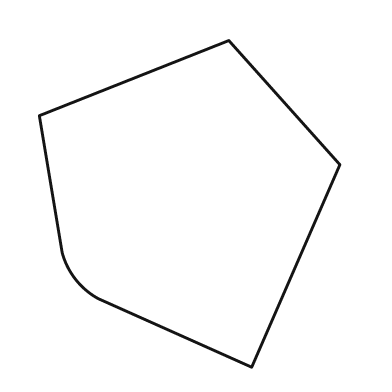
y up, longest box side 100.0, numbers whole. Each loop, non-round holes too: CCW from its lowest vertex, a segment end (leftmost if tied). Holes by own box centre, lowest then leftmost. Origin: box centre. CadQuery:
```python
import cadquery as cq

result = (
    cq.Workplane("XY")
    .moveTo(19.0, -50.0)
    .lineTo(46.0, 12.0)
    .lineTo(12.0, 50.0)
    .lineTo(-46.0, 27.0)
    .lineTo(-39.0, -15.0)
    .threePointArc((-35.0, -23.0), (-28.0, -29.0))
    .close()
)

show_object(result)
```